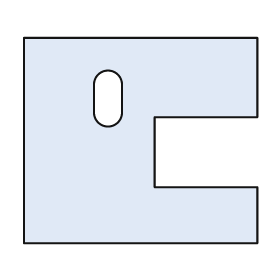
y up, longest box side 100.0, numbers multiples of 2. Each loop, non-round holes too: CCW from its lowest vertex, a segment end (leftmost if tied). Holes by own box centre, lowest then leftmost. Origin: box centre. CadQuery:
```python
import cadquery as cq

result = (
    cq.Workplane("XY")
    .moveTo(-50.0, -44.0)
    .lineTo(50.0, -44.0)
    .lineTo(50.0, -20.0)
    .lineTo(6.0, -20.0)
    .lineTo(6.0, 10.0)
    .lineTo(50.0, 10.0)
    .lineTo(50.0, 44.0)
    .lineTo(-50.0, 44.0)
    .close()
    .moveTo(-20.0, 12.0)
    .threePointArc((-14.0, 6.0), (-8.0, 12.0))
    .lineTo(-8.0, 24.0)
    .threePointArc((-14.0, 30.0), (-20.0, 24.0))
    .close()
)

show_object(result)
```